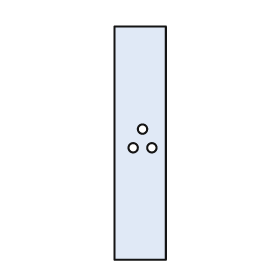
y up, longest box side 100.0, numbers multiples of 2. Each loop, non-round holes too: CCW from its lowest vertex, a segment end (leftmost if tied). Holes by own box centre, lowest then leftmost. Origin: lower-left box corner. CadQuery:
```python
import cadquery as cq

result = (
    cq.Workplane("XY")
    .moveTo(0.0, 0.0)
    .lineTo(22.0, 0.0)
    .lineTo(22.0, 100.0)
    .lineTo(0.0, 100.0)
    .close()
    .moveTo(8.0, 48.0)
    .circle(2.0)
    .moveTo(16.0, 48.0)
    .circle(2.0)
    .moveTo(12.0, 56.0)
    .circle(2.0)
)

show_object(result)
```